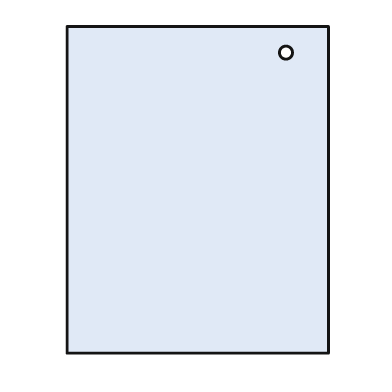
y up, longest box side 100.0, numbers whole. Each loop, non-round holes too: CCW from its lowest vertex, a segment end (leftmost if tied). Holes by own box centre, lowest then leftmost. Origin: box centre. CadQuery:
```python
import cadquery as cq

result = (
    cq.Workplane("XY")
    .moveTo(-40.0, -50.0)
    .lineTo(40.0, -50.0)
    .lineTo(40.0, 50.0)
    .lineTo(-40.0, 50.0)
    .close()
    .moveTo(27.0, 42.0)
    .circle(2.0)
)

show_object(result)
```